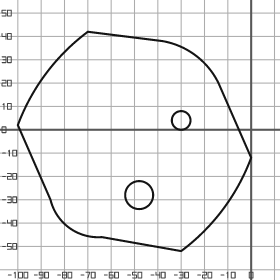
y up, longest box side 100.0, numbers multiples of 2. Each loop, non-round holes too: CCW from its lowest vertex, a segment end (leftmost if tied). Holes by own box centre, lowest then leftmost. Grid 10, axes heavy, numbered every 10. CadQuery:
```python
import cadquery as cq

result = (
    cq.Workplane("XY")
    .moveTo(-30.0, -52.0)
    .threePointArc((-12.0, -34.0), (0.0, -12.0))
    .lineTo(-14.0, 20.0)
    .threePointArc((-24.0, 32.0), (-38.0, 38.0))
    .lineTo(-70.0, 42.0)
    .threePointArc((-88.0, 24.0), (-100.0, 2.0))
    .lineTo(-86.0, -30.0)
    .threePointArc((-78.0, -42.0), (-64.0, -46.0))
    .close()
    .moveTo(-48.0, -28.0)
    .circle(6.0)
    .moveTo(-30.0, 4.0)
    .circle(4.0)
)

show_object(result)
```